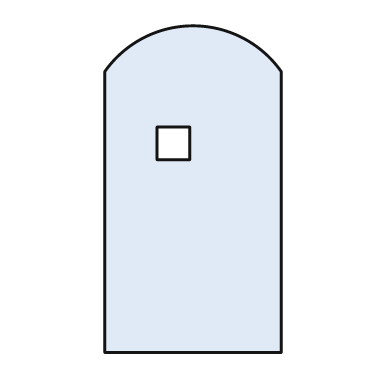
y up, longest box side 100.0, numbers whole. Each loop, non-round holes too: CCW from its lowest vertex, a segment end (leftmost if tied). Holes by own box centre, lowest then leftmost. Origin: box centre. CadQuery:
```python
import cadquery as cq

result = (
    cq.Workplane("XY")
    .moveTo(-27.0, -50.0)
    .lineTo(27.0, -50.0)
    .lineTo(27.0, 36.0)
    .threePointArc((0.0, 50.0), (-27.0, 36.0))
    .close()
    .moveTo(-11.0, 9.0)
    .lineTo(-1.0, 9.0)
    .lineTo(-1.0, 19.0)
    .lineTo(-11.0, 19.0)
    .close()
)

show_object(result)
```